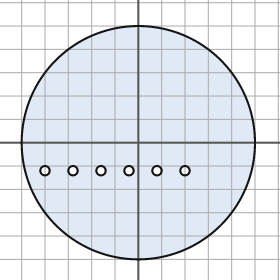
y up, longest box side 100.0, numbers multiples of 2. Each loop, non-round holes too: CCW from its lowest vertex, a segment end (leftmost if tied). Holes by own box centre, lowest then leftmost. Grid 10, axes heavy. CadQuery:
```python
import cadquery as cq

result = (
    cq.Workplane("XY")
    .moveTo(0.0, 0.0)
    .circle(50.0)
    .moveTo(-40.0, -12.0)
    .circle(2.0)
    .moveTo(-28.0, -12.0)
    .circle(2.0)
    .moveTo(-16.0, -12.0)
    .circle(2.0)
    .moveTo(-4.0, -12.0)
    .circle(2.0)
    .moveTo(8.0, -12.0)
    .circle(2.0)
    .moveTo(20.0, -12.0)
    .circle(2.0)
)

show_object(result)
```